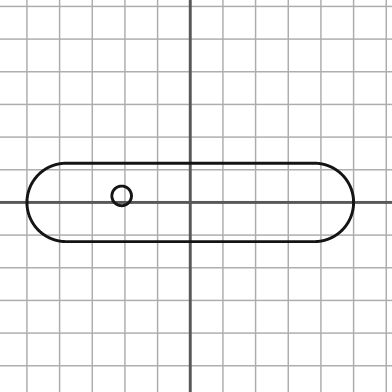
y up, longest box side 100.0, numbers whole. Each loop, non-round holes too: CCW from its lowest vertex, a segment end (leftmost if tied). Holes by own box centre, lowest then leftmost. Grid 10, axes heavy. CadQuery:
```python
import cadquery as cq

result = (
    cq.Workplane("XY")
    .moveTo(-38.0, -12.0)
    .lineTo(38.0, -12.0)
    .threePointArc((50.0, 0.0), (38.0, 12.0))
    .lineTo(-38.0, 12.0)
    .threePointArc((-50.0, 0.0), (-38.0, -12.0))
    .close()
    .moveTo(-21.0, 2.0)
    .circle(3.0)
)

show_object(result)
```